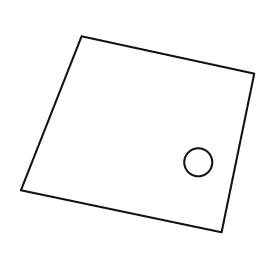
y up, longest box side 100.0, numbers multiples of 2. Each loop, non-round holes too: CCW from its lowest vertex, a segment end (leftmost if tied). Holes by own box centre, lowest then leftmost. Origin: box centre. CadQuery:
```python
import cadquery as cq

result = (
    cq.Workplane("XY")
    .moveTo(36.0, -42.0)
    .lineTo(50.0, 26.0)
    .lineTo(-24.0, 42.0)
    .lineTo(-50.0, -24.0)
    .close()
    .moveTo(26.0, -12.0)
    .circle(6.0)
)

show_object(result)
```